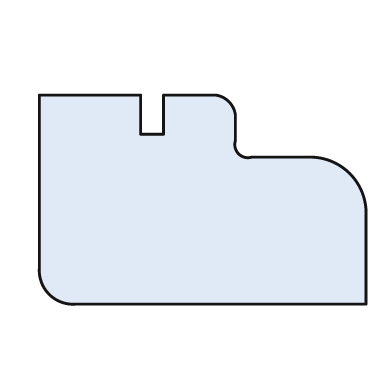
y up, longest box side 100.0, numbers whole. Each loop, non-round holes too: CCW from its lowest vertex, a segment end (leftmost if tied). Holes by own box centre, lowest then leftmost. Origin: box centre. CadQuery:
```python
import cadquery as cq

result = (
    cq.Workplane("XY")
    .moveTo(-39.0, -32.0)
    .lineTo(50.0, -32.0)
    .lineTo(50.0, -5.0)
    .threePointArc((45.0, 8.0), (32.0, 13.0))
    .lineTo(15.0, 13.0)
    .threePointArc((11.0, 14.0), (10.0, 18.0))
    .lineTo(10.0, 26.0)
    .threePointArc((8.0, 30.0), (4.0, 32.0))
    .lineTo(-12.0, 32.0)
    .lineTo(-12.0, 20.0)
    .lineTo(-19.0, 20.0)
    .lineTo(-19.0, 32.0)
    .lineTo(-50.0, 32.0)
    .lineTo(-50.0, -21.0)
    .threePointArc((-47.0, -29.0), (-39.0, -32.0))
    .close()
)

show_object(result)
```